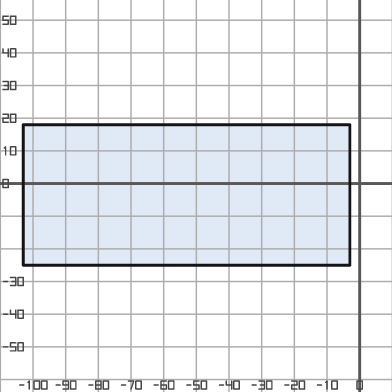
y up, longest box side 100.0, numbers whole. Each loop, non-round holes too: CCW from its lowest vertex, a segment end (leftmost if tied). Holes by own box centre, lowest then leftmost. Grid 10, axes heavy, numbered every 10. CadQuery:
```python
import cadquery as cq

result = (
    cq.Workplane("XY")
    .moveTo(-103.0, -25.0)
    .lineTo(-3.0, -25.0)
    .lineTo(-3.0, 18.0)
    .lineTo(-103.0, 18.0)
    .close()
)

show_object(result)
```